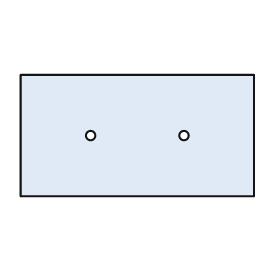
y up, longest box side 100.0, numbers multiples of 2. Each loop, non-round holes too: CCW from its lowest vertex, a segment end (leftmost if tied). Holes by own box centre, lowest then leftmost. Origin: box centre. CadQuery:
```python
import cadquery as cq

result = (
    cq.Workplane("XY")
    .moveTo(-50.0, -26.0)
    .lineTo(50.0, -26.0)
    .lineTo(50.0, 26.0)
    .lineTo(-50.0, 26.0)
    .close()
    .moveTo(-20.0, 0.0)
    .circle(2.0)
    .moveTo(20.0, 0.0)
    .circle(2.0)
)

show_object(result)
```